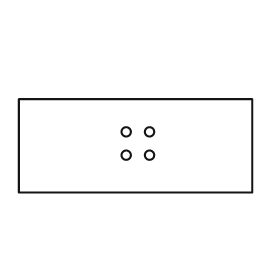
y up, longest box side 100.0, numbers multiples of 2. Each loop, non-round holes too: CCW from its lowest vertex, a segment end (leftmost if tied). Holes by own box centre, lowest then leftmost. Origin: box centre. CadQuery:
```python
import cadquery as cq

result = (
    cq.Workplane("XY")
    .moveTo(-50.0, -20.0)
    .lineTo(50.0, -20.0)
    .lineTo(50.0, 20.0)
    .lineTo(-50.0, 20.0)
    .close()
    .moveTo(-4.0, -4.0)
    .circle(2.0)
    .moveTo(6.0, -4.0)
    .circle(2.0)
    .moveTo(-4.0, 6.0)
    .circle(2.0)
    .moveTo(6.0, 6.0)
    .circle(2.0)
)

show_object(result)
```